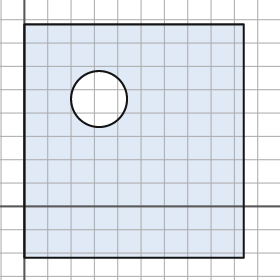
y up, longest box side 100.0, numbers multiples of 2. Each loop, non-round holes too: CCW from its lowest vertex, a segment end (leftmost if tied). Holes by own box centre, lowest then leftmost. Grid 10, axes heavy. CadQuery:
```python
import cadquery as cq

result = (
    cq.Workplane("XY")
    .moveTo(0.0, -22.0)
    .lineTo(94.0, -22.0)
    .lineTo(94.0, 78.0)
    .lineTo(0.0, 78.0)
    .close()
    .moveTo(32.0, 46.0)
    .circle(12.0)
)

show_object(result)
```